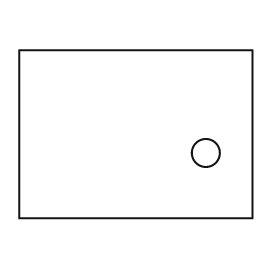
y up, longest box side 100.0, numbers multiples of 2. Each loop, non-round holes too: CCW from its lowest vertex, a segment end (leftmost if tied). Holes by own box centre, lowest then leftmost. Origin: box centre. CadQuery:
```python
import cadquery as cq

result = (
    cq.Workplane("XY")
    .moveTo(-50.0, -36.0)
    .lineTo(50.0, -36.0)
    .lineTo(50.0, 36.0)
    .lineTo(-50.0, 36.0)
    .close()
    .moveTo(30.0, -8.0)
    .circle(6.0)
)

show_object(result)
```